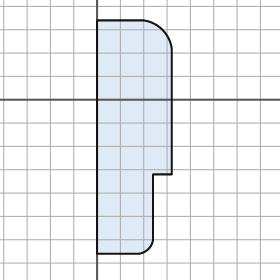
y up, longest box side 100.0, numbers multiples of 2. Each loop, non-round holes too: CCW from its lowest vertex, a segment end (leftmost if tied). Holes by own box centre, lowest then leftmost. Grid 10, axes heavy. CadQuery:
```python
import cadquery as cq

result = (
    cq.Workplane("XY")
    .moveTo(0.0, -66.0)
    .lineTo(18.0, -66.0)
    .threePointArc((22.0, -64.0), (24.0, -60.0))
    .lineTo(24.0, -32.0)
    .lineTo(32.0, -32.0)
    .lineTo(32.0, 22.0)
    .threePointArc((28.0, 30.0), (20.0, 34.0))
    .lineTo(0.0, 34.0)
    .close()
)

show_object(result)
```